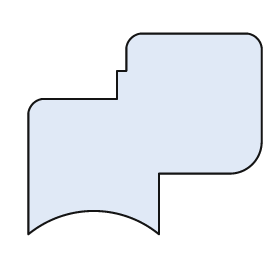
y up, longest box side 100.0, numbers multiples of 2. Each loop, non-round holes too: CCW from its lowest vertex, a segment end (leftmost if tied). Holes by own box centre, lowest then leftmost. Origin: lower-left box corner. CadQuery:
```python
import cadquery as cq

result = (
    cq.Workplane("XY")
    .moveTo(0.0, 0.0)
    .threePointArc((28.0, 10.0), (56.0, 0.0))
    .lineTo(56.0, 26.0)
    .lineTo(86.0, 26.0)
    .threePointArc((96.0, 30.0), (100.0, 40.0))
    .lineTo(100.0, 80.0)
    .threePointArc((98.0, 84.0), (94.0, 86.0))
    .lineTo(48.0, 86.0)
    .threePointArc((44.0, 84.0), (42.0, 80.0))
    .lineTo(42.0, 70.0)
    .lineTo(38.0, 70.0)
    .lineTo(38.0, 58.0)
    .lineTo(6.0, 58.0)
    .threePointArc((2.0, 56.0), (0.0, 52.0))
    .close()
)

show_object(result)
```